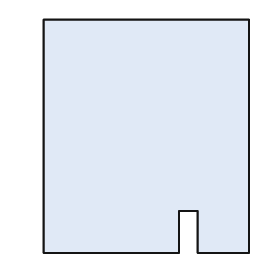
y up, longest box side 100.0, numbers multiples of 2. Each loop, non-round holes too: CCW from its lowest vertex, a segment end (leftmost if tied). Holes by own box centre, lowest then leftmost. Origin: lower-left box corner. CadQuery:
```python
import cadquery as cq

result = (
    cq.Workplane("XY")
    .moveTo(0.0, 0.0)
    .lineTo(58.0, 0.0)
    .lineTo(58.0, 18.0)
    .lineTo(66.0, 18.0)
    .lineTo(66.0, 0.0)
    .lineTo(88.0, 0.0)
    .lineTo(88.0, 100.0)
    .lineTo(0.0, 100.0)
    .close()
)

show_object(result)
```